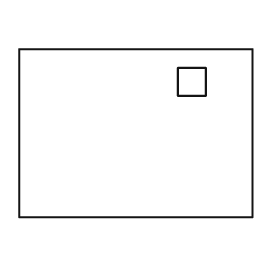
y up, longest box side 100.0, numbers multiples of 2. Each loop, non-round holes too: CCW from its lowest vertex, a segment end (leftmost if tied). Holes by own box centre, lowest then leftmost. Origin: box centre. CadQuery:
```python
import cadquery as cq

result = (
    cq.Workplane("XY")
    .moveTo(-50.0, -36.0)
    .lineTo(50.0, -36.0)
    .lineTo(50.0, 36.0)
    .lineTo(-50.0, 36.0)
    .close()
    .moveTo(18.0, 16.0)
    .lineTo(30.0, 16.0)
    .lineTo(30.0, 28.0)
    .lineTo(18.0, 28.0)
    .close()
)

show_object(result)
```